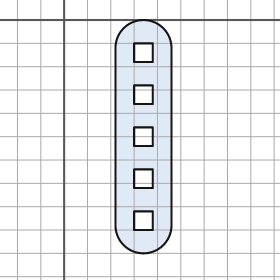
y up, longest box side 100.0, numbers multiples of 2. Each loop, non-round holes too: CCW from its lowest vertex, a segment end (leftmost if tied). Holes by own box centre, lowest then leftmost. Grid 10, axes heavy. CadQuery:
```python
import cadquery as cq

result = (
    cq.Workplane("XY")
    .moveTo(22.0, -88.0)
    .threePointArc((34.0, -100.0), (46.0, -88.0))
    .lineTo(46.0, -12.0)
    .threePointArc((34.0, 0.0), (22.0, -12.0))
    .close()
    .moveTo(30.0, -90.0)
    .lineTo(38.0, -90.0)
    .lineTo(38.0, -82.0)
    .lineTo(30.0, -82.0)
    .close()
    .moveTo(30.0, -72.0)
    .lineTo(38.0, -72.0)
    .lineTo(38.0, -64.0)
    .lineTo(30.0, -64.0)
    .close()
    .moveTo(30.0, -54.0)
    .lineTo(38.0, -54.0)
    .lineTo(38.0, -46.0)
    .lineTo(30.0, -46.0)
    .close()
    .moveTo(30.0, -36.0)
    .lineTo(38.0, -36.0)
    .lineTo(38.0, -28.0)
    .lineTo(30.0, -28.0)
    .close()
    .moveTo(30.0, -18.0)
    .lineTo(38.0, -18.0)
    .lineTo(38.0, -10.0)
    .lineTo(30.0, -10.0)
    .close()
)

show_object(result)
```